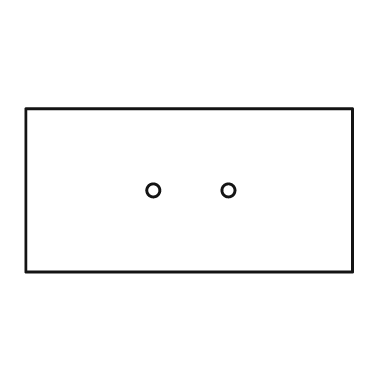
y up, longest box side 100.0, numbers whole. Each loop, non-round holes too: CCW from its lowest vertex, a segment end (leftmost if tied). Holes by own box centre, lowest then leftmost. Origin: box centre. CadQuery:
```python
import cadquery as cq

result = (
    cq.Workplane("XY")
    .moveTo(-50.0, -25.0)
    .lineTo(50.0, -25.0)
    .lineTo(50.0, 25.0)
    .lineTo(-50.0, 25.0)
    .close()
    .moveTo(-11.0, 0.0)
    .circle(2.0)
    .moveTo(12.0, 0.0)
    .circle(2.0)
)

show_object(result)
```